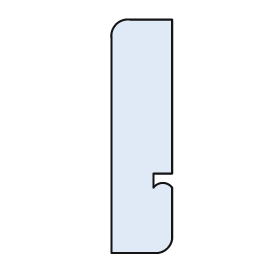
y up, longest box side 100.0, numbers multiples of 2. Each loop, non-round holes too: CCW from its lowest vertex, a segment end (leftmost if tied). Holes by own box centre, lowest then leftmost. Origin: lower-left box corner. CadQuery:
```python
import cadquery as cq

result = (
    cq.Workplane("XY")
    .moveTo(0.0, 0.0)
    .lineTo(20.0, 0.0)
    .threePointArc((24.0, 2.0), (26.0, 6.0))
    .lineTo(26.0, 28.0)
    .threePointArc((22.0, 30.0), (18.0, 28.0))
    .lineTo(18.0, 34.0)
    .lineTo(26.0, 34.0)
    .lineTo(26.0, 100.0)
    .lineTo(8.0, 100.0)
    .threePointArc((2.0, 98.0), (0.0, 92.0))
    .close()
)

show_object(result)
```